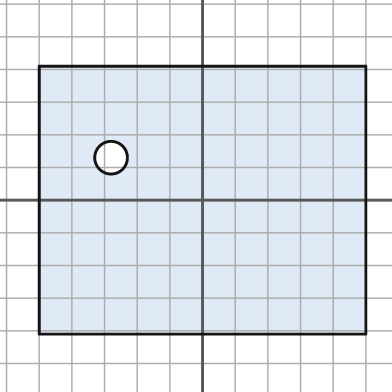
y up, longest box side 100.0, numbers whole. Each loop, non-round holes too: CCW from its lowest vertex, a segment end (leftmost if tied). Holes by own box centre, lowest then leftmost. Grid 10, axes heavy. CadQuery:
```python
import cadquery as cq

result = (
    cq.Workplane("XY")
    .moveTo(-50.0, -41.0)
    .lineTo(50.0, -41.0)
    .lineTo(50.0, 41.0)
    .lineTo(-50.0, 41.0)
    .close()
    .moveTo(-28.0, 13.0)
    .circle(5.0)
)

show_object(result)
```